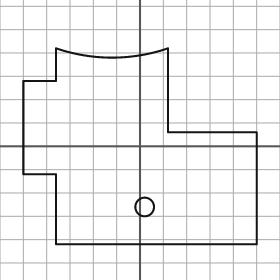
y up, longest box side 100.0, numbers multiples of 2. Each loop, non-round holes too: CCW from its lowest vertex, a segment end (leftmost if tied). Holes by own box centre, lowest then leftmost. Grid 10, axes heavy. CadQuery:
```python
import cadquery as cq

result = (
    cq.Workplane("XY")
    .moveTo(-36.0, -42.0)
    .lineTo(50.0, -42.0)
    .lineTo(50.0, 6.0)
    .lineTo(12.0, 6.0)
    .lineTo(12.0, 42.0)
    .threePointArc((-12.0, 38.0), (-36.0, 42.0))
    .lineTo(-36.0, 28.0)
    .lineTo(-50.0, 28.0)
    .lineTo(-50.0, -12.0)
    .lineTo(-36.0, -12.0)
    .close()
    .moveTo(2.0, -26.0)
    .circle(4.0)
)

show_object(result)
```